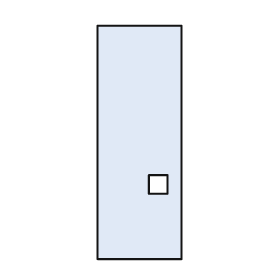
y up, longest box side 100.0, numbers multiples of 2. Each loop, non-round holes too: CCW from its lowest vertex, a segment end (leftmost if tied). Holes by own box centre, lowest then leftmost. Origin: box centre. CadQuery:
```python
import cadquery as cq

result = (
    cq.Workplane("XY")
    .moveTo(-18.0, -50.0)
    .lineTo(18.0, -50.0)
    .lineTo(18.0, 50.0)
    .lineTo(-18.0, 50.0)
    .close()
    .moveTo(4.0, -22.0)
    .lineTo(12.0, -22.0)
    .lineTo(12.0, -14.0)
    .lineTo(4.0, -14.0)
    .close()
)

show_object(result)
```